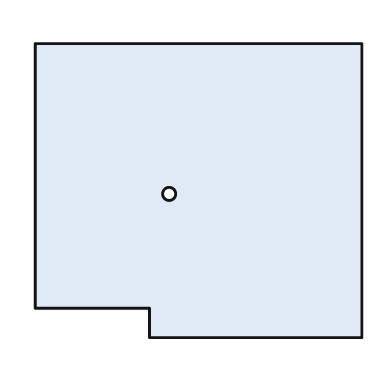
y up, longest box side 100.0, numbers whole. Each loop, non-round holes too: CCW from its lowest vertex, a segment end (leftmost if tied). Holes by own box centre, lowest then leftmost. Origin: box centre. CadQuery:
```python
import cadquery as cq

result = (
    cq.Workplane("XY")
    .moveTo(-15.0, -45.0)
    .lineTo(50.0, -45.0)
    .lineTo(50.0, 45.0)
    .lineTo(-50.0, 45.0)
    .lineTo(-50.0, -36.0)
    .lineTo(-15.0, -36.0)
    .close()
    .moveTo(-9.0, -1.0)
    .circle(2.0)
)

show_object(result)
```